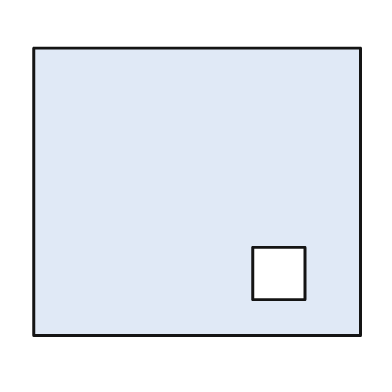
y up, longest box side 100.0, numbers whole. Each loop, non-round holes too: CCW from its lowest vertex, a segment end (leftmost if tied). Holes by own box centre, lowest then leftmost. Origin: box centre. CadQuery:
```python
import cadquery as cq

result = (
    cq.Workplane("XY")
    .moveTo(-50.0, -44.0)
    .lineTo(50.0, -44.0)
    .lineTo(50.0, 44.0)
    .lineTo(-50.0, 44.0)
    .close()
    .moveTo(17.0, -33.0)
    .lineTo(33.0, -33.0)
    .lineTo(33.0, -17.0)
    .lineTo(17.0, -17.0)
    .close()
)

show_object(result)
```